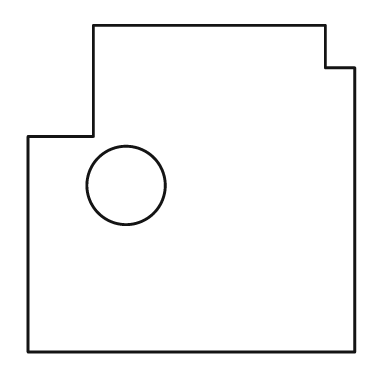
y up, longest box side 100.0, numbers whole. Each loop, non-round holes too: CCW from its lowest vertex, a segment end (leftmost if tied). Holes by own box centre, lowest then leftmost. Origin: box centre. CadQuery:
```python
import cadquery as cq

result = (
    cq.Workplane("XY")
    .moveTo(-50.0, -50.0)
    .lineTo(50.0, -50.0)
    .lineTo(50.0, 37.0)
    .lineTo(41.0, 37.0)
    .lineTo(41.0, 50.0)
    .lineTo(-30.0, 50.0)
    .lineTo(-30.0, 16.0)
    .lineTo(-50.0, 16.0)
    .close()
    .moveTo(-20.0, 1.0)
    .circle(12.0)
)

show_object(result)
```